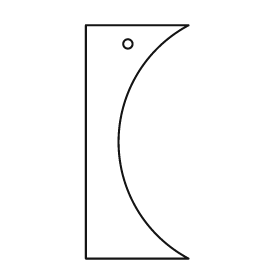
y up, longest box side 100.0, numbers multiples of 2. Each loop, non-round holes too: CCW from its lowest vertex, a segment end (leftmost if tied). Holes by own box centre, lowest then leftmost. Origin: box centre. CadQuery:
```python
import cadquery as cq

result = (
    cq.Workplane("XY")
    .moveTo(-22.0, -50.0)
    .lineTo(22.0, -50.0)
    .threePointArc((-8.0, 0.0), (22.0, 50.0))
    .lineTo(-22.0, 50.0)
    .close()
    .moveTo(-4.0, 42.0)
    .circle(2.0)
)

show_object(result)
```